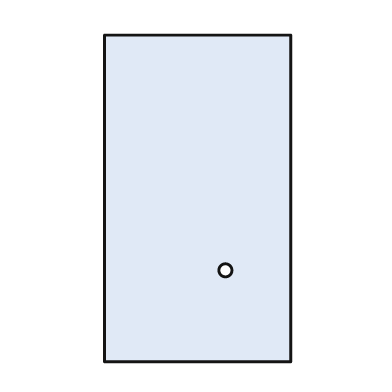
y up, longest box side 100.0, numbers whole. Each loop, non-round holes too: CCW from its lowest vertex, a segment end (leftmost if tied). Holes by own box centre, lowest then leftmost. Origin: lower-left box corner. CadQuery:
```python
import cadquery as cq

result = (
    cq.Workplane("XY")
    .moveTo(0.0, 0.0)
    .lineTo(57.0, 0.0)
    .lineTo(57.0, 100.0)
    .lineTo(0.0, 100.0)
    .close()
    .moveTo(37.0, 28.0)
    .circle(2.0)
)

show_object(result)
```